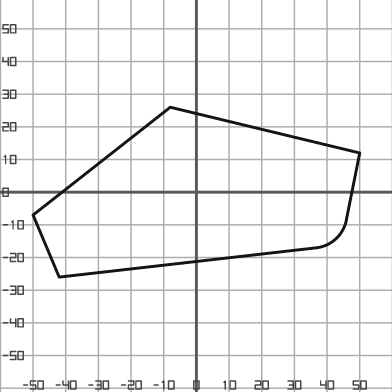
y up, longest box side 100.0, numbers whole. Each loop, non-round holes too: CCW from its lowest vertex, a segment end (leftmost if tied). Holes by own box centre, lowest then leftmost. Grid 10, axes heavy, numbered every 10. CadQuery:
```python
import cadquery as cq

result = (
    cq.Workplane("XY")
    .moveTo(-42.0, -26.0)
    .lineTo(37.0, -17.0)
    .threePointArc((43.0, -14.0), (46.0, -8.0))
    .lineTo(50.0, 12.0)
    .lineTo(-8.0, 26.0)
    .lineTo(-50.0, -7.0)
    .close()
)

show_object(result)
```